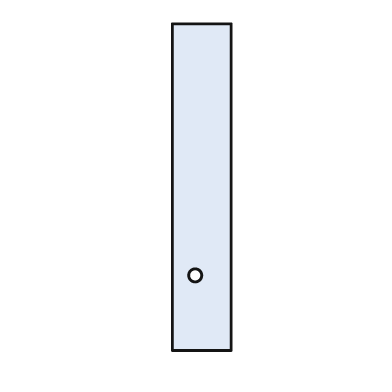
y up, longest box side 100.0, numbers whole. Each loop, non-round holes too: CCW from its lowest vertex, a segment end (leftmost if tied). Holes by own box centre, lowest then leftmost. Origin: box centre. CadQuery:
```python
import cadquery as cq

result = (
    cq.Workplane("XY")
    .moveTo(-9.0, -50.0)
    .lineTo(9.0, -50.0)
    .lineTo(9.0, 50.0)
    .lineTo(-9.0, 50.0)
    .close()
    .moveTo(-2.0, -27.0)
    .circle(2.0)
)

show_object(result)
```